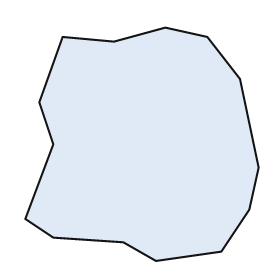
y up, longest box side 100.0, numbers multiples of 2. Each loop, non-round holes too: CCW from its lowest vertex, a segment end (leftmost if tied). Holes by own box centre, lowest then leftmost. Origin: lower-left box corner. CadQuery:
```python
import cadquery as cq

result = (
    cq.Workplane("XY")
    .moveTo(56.0, 0.0)
    .lineTo(84.0, 4.0)
    .lineTo(96.0, 22.0)
    .lineTo(100.0, 40.0)
    .lineTo(92.0, 78.0)
    .lineTo(78.0, 96.0)
    .lineTo(60.0, 100.0)
    .lineTo(38.0, 94.0)
    .lineTo(16.0, 96.0)
    .lineTo(6.0, 68.0)
    .lineTo(12.0, 50.0)
    .lineTo(0.0, 18.0)
    .lineTo(12.0, 10.0)
    .lineTo(42.0, 8.0)
    .close()
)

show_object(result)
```